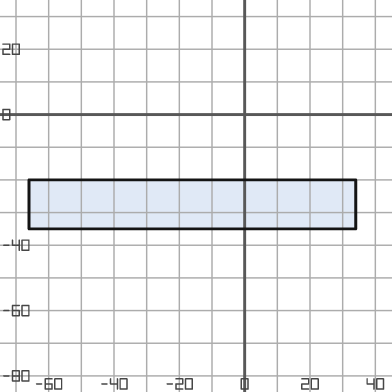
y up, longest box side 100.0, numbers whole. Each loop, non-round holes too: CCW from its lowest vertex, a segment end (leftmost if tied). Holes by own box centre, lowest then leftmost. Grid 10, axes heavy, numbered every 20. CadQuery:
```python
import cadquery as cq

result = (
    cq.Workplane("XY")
    .moveTo(-66.0, -35.0)
    .lineTo(34.0, -35.0)
    .lineTo(34.0, -20.0)
    .lineTo(-66.0, -20.0)
    .close()
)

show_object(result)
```